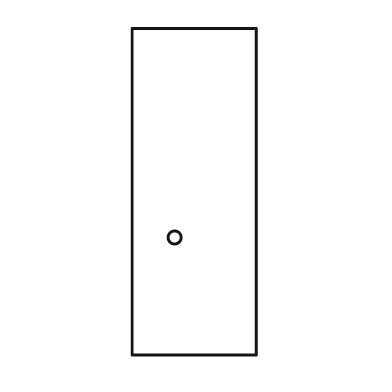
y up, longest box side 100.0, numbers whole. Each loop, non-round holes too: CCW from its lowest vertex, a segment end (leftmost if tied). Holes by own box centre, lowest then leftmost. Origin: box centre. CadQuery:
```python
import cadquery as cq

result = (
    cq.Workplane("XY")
    .moveTo(-19.0, -50.0)
    .lineTo(19.0, -50.0)
    .lineTo(19.0, 50.0)
    .lineTo(-19.0, 50.0)
    .close()
    .moveTo(-6.0, -14.0)
    .circle(2.0)
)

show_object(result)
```